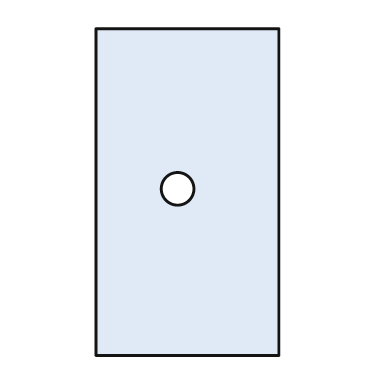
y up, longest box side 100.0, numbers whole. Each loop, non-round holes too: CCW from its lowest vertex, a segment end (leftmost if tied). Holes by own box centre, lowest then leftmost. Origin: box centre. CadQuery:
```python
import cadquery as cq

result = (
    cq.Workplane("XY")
    .moveTo(-28.0, -50.0)
    .lineTo(28.0, -50.0)
    .lineTo(28.0, 50.0)
    .lineTo(-28.0, 50.0)
    .close()
    .moveTo(-3.0, 1.0)
    .circle(5.0)
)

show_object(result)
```